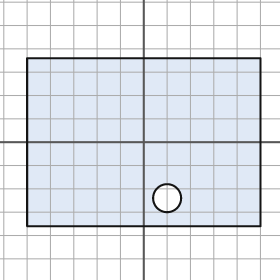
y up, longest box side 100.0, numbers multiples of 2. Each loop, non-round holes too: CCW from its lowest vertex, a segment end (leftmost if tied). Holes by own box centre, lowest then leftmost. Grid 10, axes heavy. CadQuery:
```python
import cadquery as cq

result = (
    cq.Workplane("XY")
    .moveTo(-50.0, -36.0)
    .lineTo(50.0, -36.0)
    .lineTo(50.0, 36.0)
    .lineTo(-50.0, 36.0)
    .close()
    .moveTo(10.0, -24.0)
    .circle(6.0)
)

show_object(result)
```